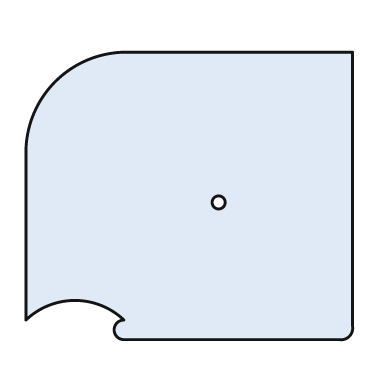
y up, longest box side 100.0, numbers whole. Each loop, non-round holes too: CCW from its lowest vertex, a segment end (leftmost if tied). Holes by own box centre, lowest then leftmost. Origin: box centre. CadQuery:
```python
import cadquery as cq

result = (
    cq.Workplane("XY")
    .moveTo(-20.0, -44.0)
    .lineTo(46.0, -44.0)
    .threePointArc((49.0, -43.0), (50.0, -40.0))
    .lineTo(50.0, 44.0)
    .lineTo(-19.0, 44.0)
    .threePointArc((-41.0, 35.0), (-50.0, 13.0))
    .lineTo(-50.0, -38.0)
    .threePointArc((-35.0, -32.0), (-20.0, -38.0))
    .threePointArc((-23.0, -41.0), (-20.0, -44.0))
    .close()
    .moveTo(9.0, -2.0)
    .circle(2.0)
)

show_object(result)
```